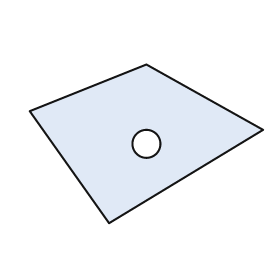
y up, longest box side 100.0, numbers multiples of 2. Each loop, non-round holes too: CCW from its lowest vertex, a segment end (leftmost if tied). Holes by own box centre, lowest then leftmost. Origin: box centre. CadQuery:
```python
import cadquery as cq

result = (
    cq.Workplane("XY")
    .moveTo(-16.0, -34.0)
    .lineTo(50.0, 6.0)
    .lineTo(0.0, 34.0)
    .lineTo(-50.0, 14.0)
    .close()
    .moveTo(0.0, 0.0)
    .circle(6.0)
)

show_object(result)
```